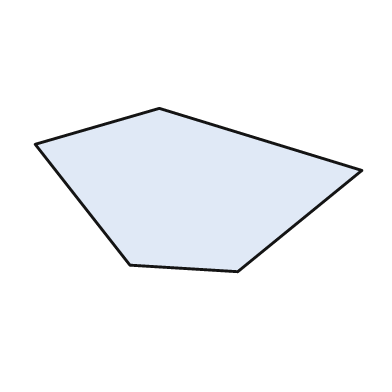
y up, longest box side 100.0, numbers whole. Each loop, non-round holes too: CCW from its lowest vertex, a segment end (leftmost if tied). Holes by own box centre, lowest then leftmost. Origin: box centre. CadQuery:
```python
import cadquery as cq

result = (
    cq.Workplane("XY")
    .moveTo(12.0, -25.0)
    .lineTo(50.0, 6.0)
    .lineTo(-12.0, 25.0)
    .lineTo(-50.0, 14.0)
    .lineTo(-21.0, -23.0)
    .close()
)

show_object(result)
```